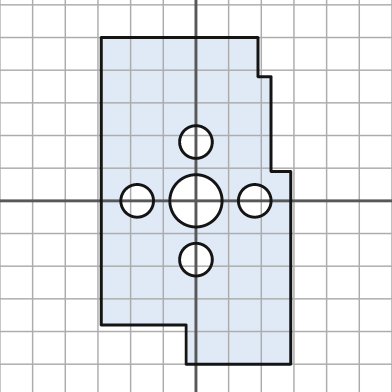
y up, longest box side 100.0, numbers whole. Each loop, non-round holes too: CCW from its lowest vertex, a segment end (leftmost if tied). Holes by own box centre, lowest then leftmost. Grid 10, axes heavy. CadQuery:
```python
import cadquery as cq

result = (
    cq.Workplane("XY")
    .moveTo(-3.0, -50.0)
    .lineTo(29.0, -50.0)
    .lineTo(29.0, 9.0)
    .lineTo(23.0, 9.0)
    .lineTo(23.0, 38.0)
    .lineTo(19.0, 38.0)
    .lineTo(19.0, 50.0)
    .lineTo(-29.0, 50.0)
    .lineTo(-29.0, -38.0)
    .lineTo(-3.0, -38.0)
    .close()
    .moveTo(0.0, -18.0)
    .circle(5.0)
    .moveTo(-18.0, 0.0)
    .circle(5.0)
    .moveTo(0.0, 0.0)
    .circle(8.0)
    .moveTo(18.0, 0.0)
    .circle(5.0)
    .moveTo(0.0, 18.0)
    .circle(5.0)
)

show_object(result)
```